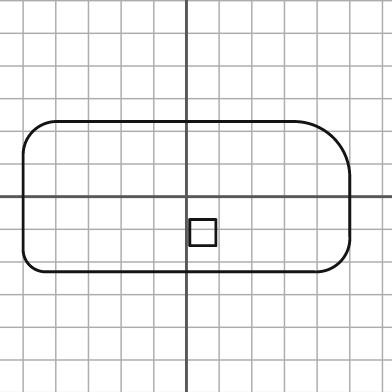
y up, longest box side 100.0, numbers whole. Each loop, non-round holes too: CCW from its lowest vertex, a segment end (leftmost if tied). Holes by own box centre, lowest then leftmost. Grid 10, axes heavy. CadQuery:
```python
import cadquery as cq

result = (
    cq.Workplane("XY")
    .moveTo(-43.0, -23.0)
    .lineTo(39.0, -23.0)
    .threePointArc((47.0, -20.0), (50.0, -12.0))
    .lineTo(50.0, 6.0)
    .threePointArc((45.0, 18.0), (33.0, 23.0))
    .lineTo(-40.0, 23.0)
    .threePointArc((-47.0, 20.0), (-50.0, 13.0))
    .lineTo(-50.0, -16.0)
    .threePointArc((-48.0, -21.0), (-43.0, -23.0))
    .close()
    .moveTo(1.0, -15.0)
    .lineTo(9.0, -15.0)
    .lineTo(9.0, -7.0)
    .lineTo(1.0, -7.0)
    .close()
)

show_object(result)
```